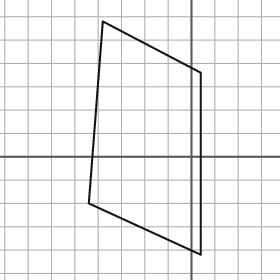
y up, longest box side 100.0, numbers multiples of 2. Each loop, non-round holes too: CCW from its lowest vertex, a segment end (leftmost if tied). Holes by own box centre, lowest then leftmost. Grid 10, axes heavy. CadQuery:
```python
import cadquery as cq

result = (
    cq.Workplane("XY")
    .moveTo(4.0, -42.0)
    .lineTo(4.0, 36.0)
    .lineTo(-38.0, 58.0)
    .lineTo(-44.0, -20.0)
    .close()
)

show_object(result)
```